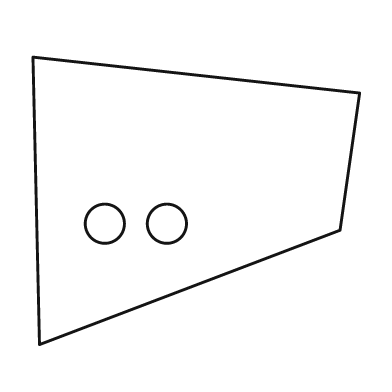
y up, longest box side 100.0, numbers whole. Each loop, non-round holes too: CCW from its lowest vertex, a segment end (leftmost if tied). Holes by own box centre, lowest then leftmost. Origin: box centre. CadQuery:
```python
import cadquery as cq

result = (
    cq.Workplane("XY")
    .moveTo(-48.0, -44.0)
    .lineTo(44.0, -9.0)
    .lineTo(50.0, 33.0)
    .lineTo(-50.0, 44.0)
    .close()
    .moveTo(-28.0, -7.0)
    .circle(6.0)
    .moveTo(-9.0, -7.0)
    .circle(6.0)
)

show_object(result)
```